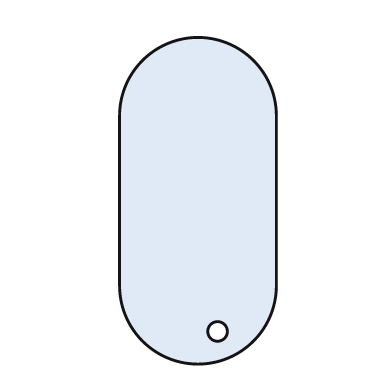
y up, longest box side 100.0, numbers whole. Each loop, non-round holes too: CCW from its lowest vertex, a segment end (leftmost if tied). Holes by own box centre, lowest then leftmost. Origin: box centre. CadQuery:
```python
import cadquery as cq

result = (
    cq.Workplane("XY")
    .moveTo(-24.0, -26.0)
    .threePointArc((0.0, -50.0), (24.0, -26.0))
    .lineTo(24.0, 26.0)
    .threePointArc((0.0, 50.0), (-24.0, 26.0))
    .close()
    .moveTo(6.0, -40.0)
    .circle(3.0)
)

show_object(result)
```